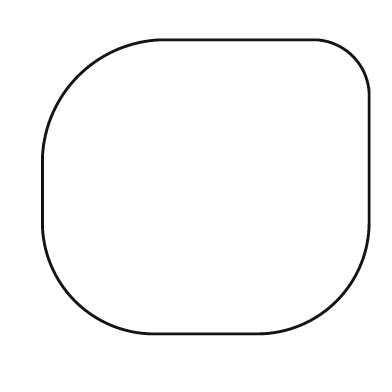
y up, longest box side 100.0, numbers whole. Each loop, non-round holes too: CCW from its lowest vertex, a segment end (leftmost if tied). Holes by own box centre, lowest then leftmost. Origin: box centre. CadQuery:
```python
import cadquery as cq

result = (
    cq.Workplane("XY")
    .moveTo(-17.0, -45.0)
    .lineTo(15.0, -45.0)
    .threePointArc((40.0, -35.0), (50.0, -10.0))
    .lineTo(50.0, 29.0)
    .threePointArc((45.0, 40.0), (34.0, 45.0))
    .lineTo(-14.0, 45.0)
    .threePointArc((-39.0, 34.0), (-50.0, 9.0))
    .lineTo(-50.0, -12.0)
    .threePointArc((-40.0, -35.0), (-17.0, -45.0))
    .close()
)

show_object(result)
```